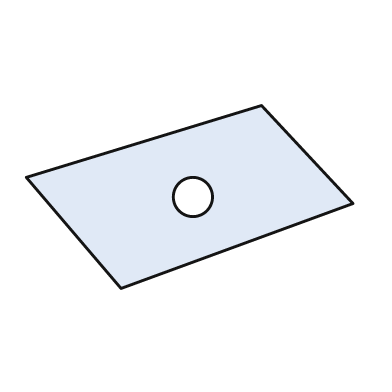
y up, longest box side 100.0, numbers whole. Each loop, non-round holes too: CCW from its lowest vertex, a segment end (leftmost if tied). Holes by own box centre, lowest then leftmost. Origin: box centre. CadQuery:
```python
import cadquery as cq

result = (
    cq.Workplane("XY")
    .moveTo(-21.0, -28.0)
    .lineTo(50.0, -2.0)
    .lineTo(22.0, 28.0)
    .lineTo(-50.0, 6.0)
    .close()
    .moveTo(1.0, 0.0)
    .circle(6.0)
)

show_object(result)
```